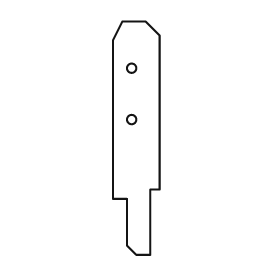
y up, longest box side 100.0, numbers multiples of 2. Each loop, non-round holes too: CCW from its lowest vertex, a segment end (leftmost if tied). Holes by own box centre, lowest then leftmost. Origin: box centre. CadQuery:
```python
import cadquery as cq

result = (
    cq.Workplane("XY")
    .moveTo(0.0, -50.0)
    .lineTo(6.0, -50.0)
    .lineTo(6.0, -22.0)
    .lineTo(10.0, -22.0)
    .lineTo(10.0, 44.0)
    .lineTo(4.0, 50.0)
    .lineTo(-6.0, 50.0)
    .lineTo(-10.0, 42.0)
    .lineTo(-10.0, -26.0)
    .lineTo(-4.0, -26.0)
    .lineTo(-4.0, -46.0)
    .close()
    .moveTo(-2.0, 8.0)
    .circle(2.0)
    .moveTo(-2.0, 30.0)
    .circle(2.0)
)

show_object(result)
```